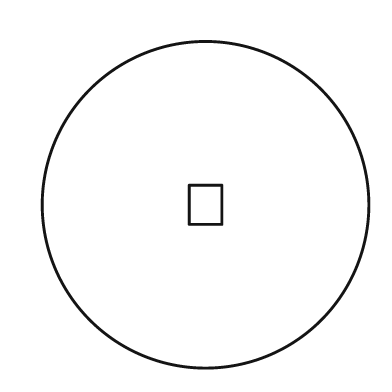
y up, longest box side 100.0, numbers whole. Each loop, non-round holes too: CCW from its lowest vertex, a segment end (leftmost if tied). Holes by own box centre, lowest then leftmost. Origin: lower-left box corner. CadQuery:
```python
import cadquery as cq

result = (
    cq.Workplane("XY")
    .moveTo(50.0, 50.0)
    .circle(50.0)
    .moveTo(45.0, 44.0)
    .lineTo(55.0, 44.0)
    .lineTo(55.0, 56.0)
    .lineTo(45.0, 56.0)
    .close()
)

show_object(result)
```